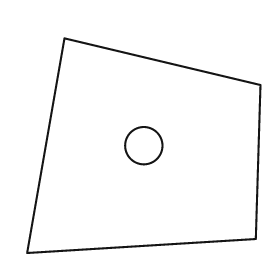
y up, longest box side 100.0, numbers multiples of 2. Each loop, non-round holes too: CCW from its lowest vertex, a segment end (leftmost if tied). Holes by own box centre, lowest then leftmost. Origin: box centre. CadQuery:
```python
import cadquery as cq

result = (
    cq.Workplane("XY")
    .moveTo(-50.0, -46.0)
    .lineTo(48.0, -40.0)
    .lineTo(50.0, 26.0)
    .lineTo(-34.0, 46.0)
    .close()
    .moveTo(0.0, 0.0)
    .circle(8.0)
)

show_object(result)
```